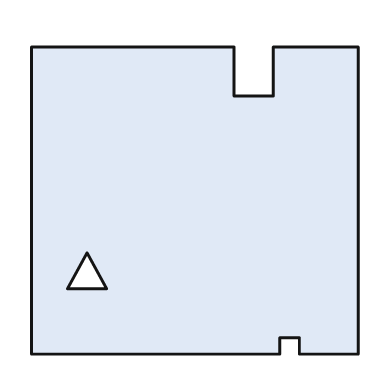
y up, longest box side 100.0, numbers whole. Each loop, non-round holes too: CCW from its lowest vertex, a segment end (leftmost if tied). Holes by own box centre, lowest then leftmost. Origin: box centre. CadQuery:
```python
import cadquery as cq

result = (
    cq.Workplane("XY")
    .moveTo(-50.0, -47.0)
    .lineTo(26.0, -47.0)
    .lineTo(26.0, -42.0)
    .lineTo(32.0, -42.0)
    .lineTo(32.0, -47.0)
    .lineTo(50.0, -47.0)
    .lineTo(50.0, 47.0)
    .lineTo(24.0, 47.0)
    .lineTo(24.0, 32.0)
    .lineTo(12.0, 32.0)
    .lineTo(12.0, 47.0)
    .lineTo(-50.0, 47.0)
    .close()
    .moveTo(-39.0, -27.0)
    .lineTo(-27.0, -27.0)
    .lineTo(-33.0, -16.0)
    .close()
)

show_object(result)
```